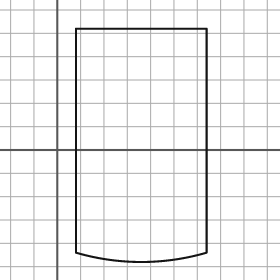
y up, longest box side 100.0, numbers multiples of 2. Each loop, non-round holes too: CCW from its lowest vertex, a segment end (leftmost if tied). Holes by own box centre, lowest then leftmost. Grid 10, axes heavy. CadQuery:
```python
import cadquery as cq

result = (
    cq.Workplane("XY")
    .moveTo(8.0, -44.0)
    .threePointArc((36.0, -48.0), (64.0, -44.0))
    .lineTo(64.0, 52.0)
    .lineTo(8.0, 52.0)
    .close()
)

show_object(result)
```